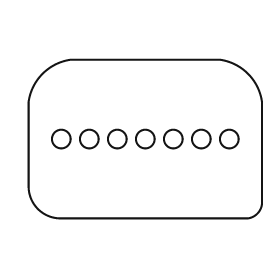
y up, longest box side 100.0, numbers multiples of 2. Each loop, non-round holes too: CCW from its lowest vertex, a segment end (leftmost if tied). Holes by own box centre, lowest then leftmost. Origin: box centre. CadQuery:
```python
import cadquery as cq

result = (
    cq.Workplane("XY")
    .moveTo(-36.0, -34.0)
    .lineTo(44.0, -34.0)
    .threePointArc((48.0, -32.0), (50.0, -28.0))
    .lineTo(50.0, 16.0)
    .threePointArc((44.0, 28.0), (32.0, 34.0))
    .lineTo(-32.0, 34.0)
    .threePointArc((-44.0, 28.0), (-50.0, 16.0))
    .lineTo(-50.0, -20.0)
    .threePointArc((-46.0, -30.0), (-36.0, -34.0))
    .close()
    .moveTo(-36.0, 0.0)
    .circle(4.0)
    .moveTo(-24.0, 0.0)
    .circle(4.0)
    .moveTo(-12.0, 0.0)
    .circle(4.0)
    .moveTo(0.0, 0.0)
    .circle(4.0)
    .moveTo(12.0, 0.0)
    .circle(4.0)
    .moveTo(24.0, 0.0)
    .circle(4.0)
    .moveTo(36.0, 0.0)
    .circle(4.0)
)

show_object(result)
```